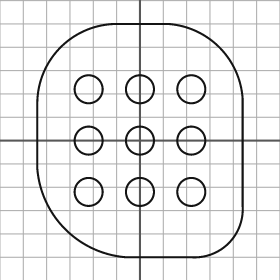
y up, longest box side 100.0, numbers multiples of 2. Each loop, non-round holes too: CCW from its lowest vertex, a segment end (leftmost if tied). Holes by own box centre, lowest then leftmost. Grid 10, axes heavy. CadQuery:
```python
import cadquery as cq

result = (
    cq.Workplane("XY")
    .moveTo(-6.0, -50.0)
    .lineTo(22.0, -50.0)
    .threePointArc((38.0, -44.0), (44.0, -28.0))
    .lineTo(44.0, 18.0)
    .threePointArc((34.0, 40.0), (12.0, 50.0))
    .lineTo(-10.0, 50.0)
    .threePointArc((-34.0, 40.0), (-44.0, 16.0))
    .lineTo(-44.0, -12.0)
    .threePointArc((-32.0, -38.0), (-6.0, -50.0))
    .close()
    .moveTo(-22.0, -22.0)
    .circle(6.0)
    .moveTo(0.0, -22.0)
    .circle(6.0)
    .moveTo(22.0, -22.0)
    .circle(6.0)
    .moveTo(-22.0, 0.0)
    .circle(6.0)
    .moveTo(0.0, 0.0)
    .circle(6.0)
    .moveTo(22.0, 0.0)
    .circle(6.0)
    .moveTo(-22.0, 22.0)
    .circle(6.0)
    .moveTo(0.0, 22.0)
    .circle(6.0)
    .moveTo(22.0, 22.0)
    .circle(6.0)
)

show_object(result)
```